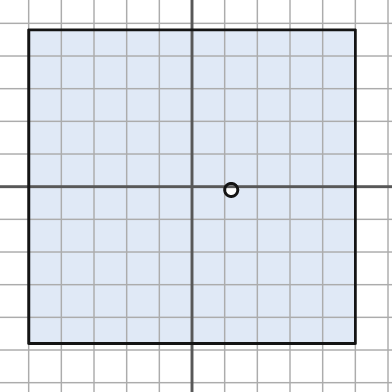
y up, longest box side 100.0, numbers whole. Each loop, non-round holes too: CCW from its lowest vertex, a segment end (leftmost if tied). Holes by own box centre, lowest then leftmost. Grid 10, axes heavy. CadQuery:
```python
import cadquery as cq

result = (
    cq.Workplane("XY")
    .moveTo(-50.0, -48.0)
    .lineTo(50.0, -48.0)
    .lineTo(50.0, 48.0)
    .lineTo(-50.0, 48.0)
    .close()
    .moveTo(12.0, -1.0)
    .circle(2.0)
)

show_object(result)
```